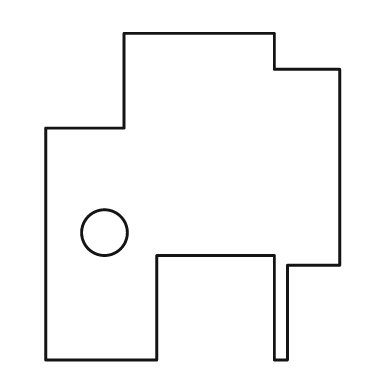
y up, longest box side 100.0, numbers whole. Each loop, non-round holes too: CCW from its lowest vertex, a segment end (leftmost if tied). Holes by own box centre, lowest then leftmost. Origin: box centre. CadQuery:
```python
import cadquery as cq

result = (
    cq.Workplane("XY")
    .moveTo(-45.0, -50.0)
    .lineTo(-11.0, -50.0)
    .lineTo(-11.0, -18.0)
    .lineTo(25.0, -18.0)
    .lineTo(25.0, -50.0)
    .lineTo(29.0, -50.0)
    .lineTo(29.0, -21.0)
    .lineTo(45.0, -21.0)
    .lineTo(45.0, 39.0)
    .lineTo(25.0, 39.0)
    .lineTo(25.0, 50.0)
    .lineTo(-21.0, 50.0)
    .lineTo(-21.0, 21.0)
    .lineTo(-45.0, 21.0)
    .close()
    .moveTo(-27.0, -11.0)
    .circle(7.0)
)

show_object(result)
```